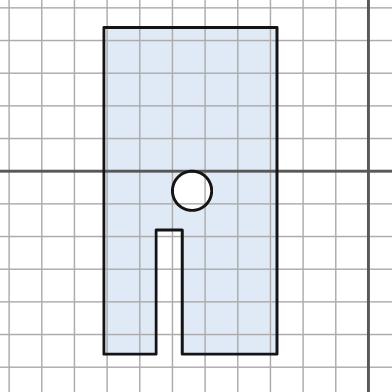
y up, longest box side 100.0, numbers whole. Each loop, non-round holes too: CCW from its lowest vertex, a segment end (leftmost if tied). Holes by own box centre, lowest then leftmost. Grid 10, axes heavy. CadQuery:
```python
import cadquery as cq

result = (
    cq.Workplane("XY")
    .moveTo(-81.0, -56.0)
    .lineTo(-65.0, -56.0)
    .lineTo(-65.0, -18.0)
    .lineTo(-57.0, -18.0)
    .lineTo(-57.0, -56.0)
    .lineTo(-28.0, -56.0)
    .lineTo(-28.0, 44.0)
    .lineTo(-81.0, 44.0)
    .close()
    .moveTo(-54.0, -6.0)
    .circle(6.0)
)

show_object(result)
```